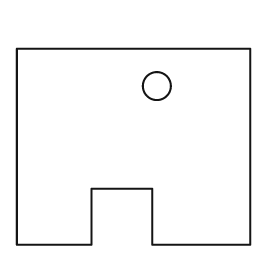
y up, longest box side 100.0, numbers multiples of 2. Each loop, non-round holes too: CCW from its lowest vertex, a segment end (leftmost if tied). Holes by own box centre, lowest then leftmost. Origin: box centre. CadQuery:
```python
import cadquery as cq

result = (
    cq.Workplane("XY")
    .moveTo(-50.0, -42.0)
    .lineTo(-18.0, -42.0)
    .lineTo(-18.0, -18.0)
    .lineTo(8.0, -18.0)
    .lineTo(8.0, -42.0)
    .lineTo(50.0, -42.0)
    .lineTo(50.0, 42.0)
    .lineTo(-50.0, 42.0)
    .close()
    .moveTo(10.0, 26.0)
    .circle(6.0)
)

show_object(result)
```